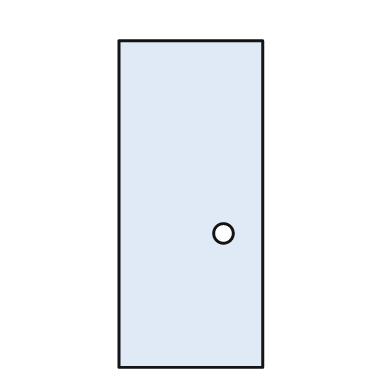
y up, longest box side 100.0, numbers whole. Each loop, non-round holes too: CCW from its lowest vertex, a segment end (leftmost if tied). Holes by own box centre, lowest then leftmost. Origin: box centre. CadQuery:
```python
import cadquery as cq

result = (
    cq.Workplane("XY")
    .moveTo(-22.0, -50.0)
    .lineTo(22.0, -50.0)
    .lineTo(22.0, 50.0)
    .lineTo(-22.0, 50.0)
    .close()
    .moveTo(10.0, -9.0)
    .circle(3.0)
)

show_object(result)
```